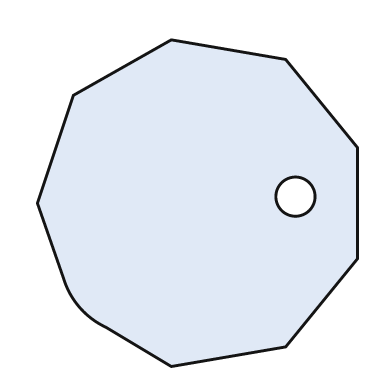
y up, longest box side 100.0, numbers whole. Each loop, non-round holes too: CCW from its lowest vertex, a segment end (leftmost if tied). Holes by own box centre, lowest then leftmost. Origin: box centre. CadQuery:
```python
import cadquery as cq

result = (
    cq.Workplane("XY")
    .moveTo(-8.0, -50.0)
    .lineTo(27.0, -44.0)
    .lineTo(49.0, -17.0)
    .lineTo(49.0, 17.0)
    .lineTo(27.0, 44.0)
    .lineTo(-8.0, 50.0)
    .lineTo(-38.0, 33.0)
    .lineTo(-49.0, 0.0)
    .lineTo(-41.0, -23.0)
    .threePointArc((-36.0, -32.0), (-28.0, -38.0))
    .close()
    .moveTo(30.0, 2.0)
    .circle(6.0)
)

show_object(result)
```